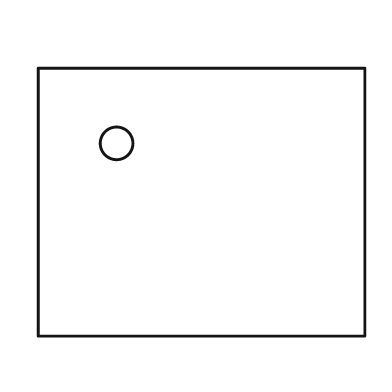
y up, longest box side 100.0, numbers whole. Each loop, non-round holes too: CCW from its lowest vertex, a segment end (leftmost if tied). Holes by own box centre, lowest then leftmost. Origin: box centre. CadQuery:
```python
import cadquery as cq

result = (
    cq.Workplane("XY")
    .moveTo(-50.0, -41.0)
    .lineTo(50.0, -41.0)
    .lineTo(50.0, 41.0)
    .lineTo(-50.0, 41.0)
    .close()
    .moveTo(-26.0, 18.0)
    .circle(5.0)
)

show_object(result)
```